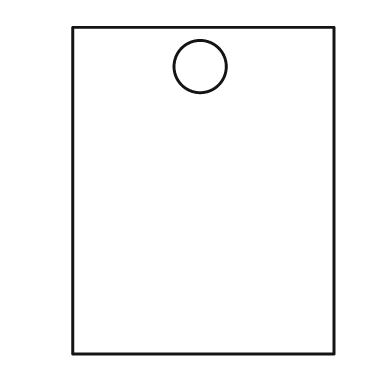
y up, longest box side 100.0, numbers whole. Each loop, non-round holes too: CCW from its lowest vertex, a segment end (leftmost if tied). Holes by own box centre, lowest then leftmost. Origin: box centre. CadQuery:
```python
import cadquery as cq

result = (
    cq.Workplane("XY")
    .moveTo(-40.0, -50.0)
    .lineTo(40.0, -50.0)
    .lineTo(40.0, 50.0)
    .lineTo(-40.0, 50.0)
    .close()
    .moveTo(-1.0, 38.0)
    .circle(8.0)
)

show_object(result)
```